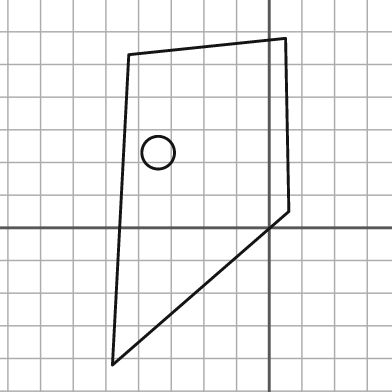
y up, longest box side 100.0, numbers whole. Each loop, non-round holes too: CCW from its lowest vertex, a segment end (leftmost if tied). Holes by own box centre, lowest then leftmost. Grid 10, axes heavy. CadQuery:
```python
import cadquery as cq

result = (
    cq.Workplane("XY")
    .moveTo(-48.0, -42.0)
    .lineTo(6.0, 5.0)
    .lineTo(5.0, 58.0)
    .lineTo(-43.0, 53.0)
    .close()
    .moveTo(-34.0, 23.0)
    .circle(5.0)
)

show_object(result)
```